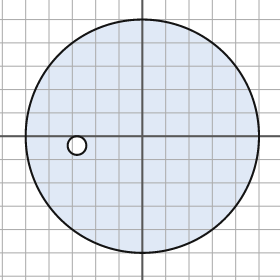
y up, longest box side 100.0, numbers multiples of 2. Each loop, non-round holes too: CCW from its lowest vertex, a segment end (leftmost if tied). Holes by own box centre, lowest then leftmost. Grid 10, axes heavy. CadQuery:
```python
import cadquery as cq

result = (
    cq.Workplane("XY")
    .moveTo(0.0, 0.0)
    .circle(50.0)
    .moveTo(-28.0, -4.0)
    .circle(4.0)
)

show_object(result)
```